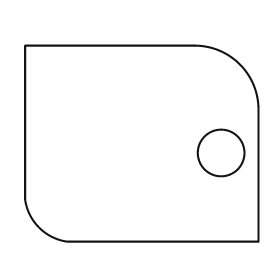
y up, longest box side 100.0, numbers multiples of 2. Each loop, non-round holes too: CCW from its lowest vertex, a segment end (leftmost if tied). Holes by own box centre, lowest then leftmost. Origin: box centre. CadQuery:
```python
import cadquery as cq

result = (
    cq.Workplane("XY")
    .moveTo(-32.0, -42.0)
    .lineTo(50.0, -42.0)
    .lineTo(50.0, 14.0)
    .threePointArc((42.0, 34.0), (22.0, 42.0))
    .lineTo(-50.0, 42.0)
    .lineTo(-50.0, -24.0)
    .threePointArc((-44.0, -36.0), (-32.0, -42.0))
    .close()
    .moveTo(34.0, -4.0)
    .circle(10.0)
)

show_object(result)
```